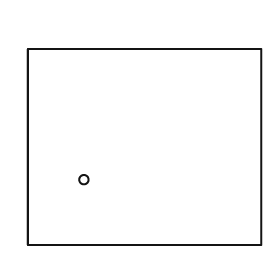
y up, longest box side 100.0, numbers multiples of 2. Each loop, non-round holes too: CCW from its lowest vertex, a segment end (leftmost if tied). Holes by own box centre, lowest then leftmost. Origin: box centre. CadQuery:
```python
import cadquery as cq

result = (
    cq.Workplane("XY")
    .moveTo(-50.0, -42.0)
    .lineTo(50.0, -42.0)
    .lineTo(50.0, 42.0)
    .lineTo(-50.0, 42.0)
    .close()
    .moveTo(-26.0, -14.0)
    .circle(2.0)
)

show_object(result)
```